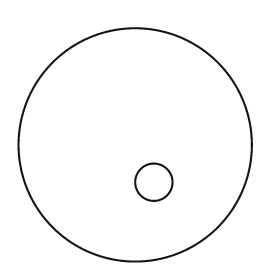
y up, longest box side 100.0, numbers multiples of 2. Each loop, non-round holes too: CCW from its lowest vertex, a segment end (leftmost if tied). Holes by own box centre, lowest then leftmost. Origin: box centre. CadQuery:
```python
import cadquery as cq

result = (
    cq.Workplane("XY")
    .moveTo(0.0, 0.0)
    .circle(50.0)
    .moveTo(8.0, -16.0)
    .circle(8.0)
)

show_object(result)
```